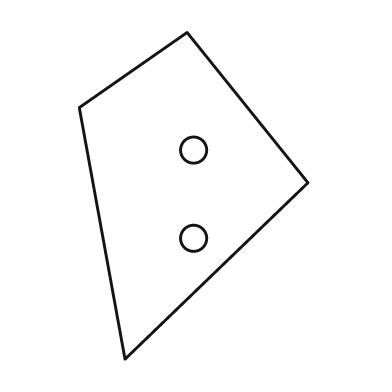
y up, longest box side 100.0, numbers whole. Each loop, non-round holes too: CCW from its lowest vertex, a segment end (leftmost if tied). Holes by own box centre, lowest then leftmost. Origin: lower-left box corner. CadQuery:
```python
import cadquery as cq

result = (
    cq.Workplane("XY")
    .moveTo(14.0, 0.0)
    .lineTo(70.0, 54.0)
    .lineTo(33.0, 100.0)
    .lineTo(0.0, 77.0)
    .close()
    .moveTo(35.0, 37.0)
    .circle(4.0)
    .moveTo(35.0, 64.0)
    .circle(4.0)
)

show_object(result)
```